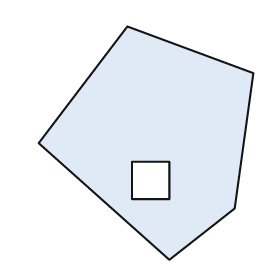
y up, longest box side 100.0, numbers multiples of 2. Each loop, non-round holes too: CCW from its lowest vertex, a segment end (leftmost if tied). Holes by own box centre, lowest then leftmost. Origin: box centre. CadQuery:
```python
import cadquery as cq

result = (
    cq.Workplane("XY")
    .moveTo(10.0, -50.0)
    .lineTo(38.0, -28.0)
    .lineTo(46.0, 30.0)
    .lineTo(-8.0, 50.0)
    .lineTo(-46.0, 0.0)
    .close()
    .moveTo(-6.0, -24.0)
    .lineTo(10.0, -24.0)
    .lineTo(10.0, -8.0)
    .lineTo(-6.0, -8.0)
    .close()
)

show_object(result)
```